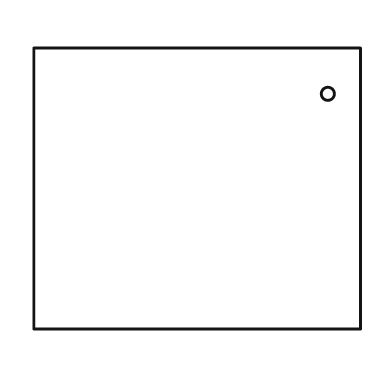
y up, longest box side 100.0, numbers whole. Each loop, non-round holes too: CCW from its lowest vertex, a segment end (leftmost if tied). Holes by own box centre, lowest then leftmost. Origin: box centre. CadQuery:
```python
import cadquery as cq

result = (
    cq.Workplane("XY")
    .moveTo(-50.0, -43.0)
    .lineTo(50.0, -43.0)
    .lineTo(50.0, 43.0)
    .lineTo(-50.0, 43.0)
    .close()
    .moveTo(40.0, 29.0)
    .circle(2.0)
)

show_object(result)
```